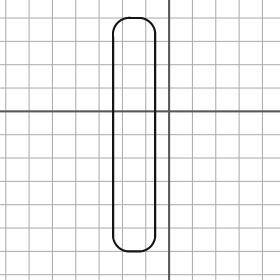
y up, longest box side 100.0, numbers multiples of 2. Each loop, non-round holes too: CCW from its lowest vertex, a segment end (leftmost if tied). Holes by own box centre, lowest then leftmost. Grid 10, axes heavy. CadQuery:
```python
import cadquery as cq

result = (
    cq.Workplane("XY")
    .moveTo(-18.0, -60.0)
    .lineTo(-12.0, -60.0)
    .threePointArc((-8.0, -58.0), (-6.0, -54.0))
    .lineTo(-6.0, 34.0)
    .threePointArc((-8.0, 38.0), (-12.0, 40.0))
    .lineTo(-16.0, 40.0)
    .threePointArc((-22.0, 38.0), (-24.0, 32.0))
    .lineTo(-24.0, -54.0)
    .threePointArc((-22.0, -58.0), (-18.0, -60.0))
    .close()
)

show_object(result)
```